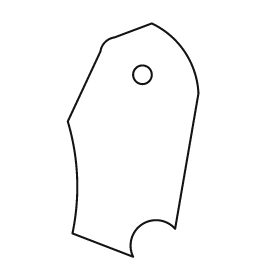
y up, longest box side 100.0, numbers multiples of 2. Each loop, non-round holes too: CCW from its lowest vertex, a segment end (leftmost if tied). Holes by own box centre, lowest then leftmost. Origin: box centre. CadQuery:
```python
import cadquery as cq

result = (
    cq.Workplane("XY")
    .moveTo(0.0, -50.0)
    .threePointArc((4.0, -36.0), (18.0, -38.0))
    .lineTo(28.0, 20.0)
    .threePointArc((22.0, 38.0), (8.0, 50.0))
    .lineTo(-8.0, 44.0)
    .threePointArc((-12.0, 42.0), (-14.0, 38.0))
    .lineTo(-28.0, 8.0)
    .threePointArc((-24.0, -16.0), (-26.0, -40.0))
    .close()
    .moveTo(4.0, 28.0)
    .circle(4.0)
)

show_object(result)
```